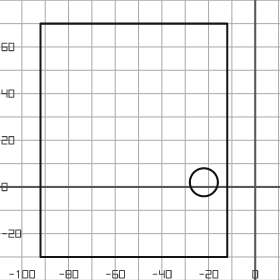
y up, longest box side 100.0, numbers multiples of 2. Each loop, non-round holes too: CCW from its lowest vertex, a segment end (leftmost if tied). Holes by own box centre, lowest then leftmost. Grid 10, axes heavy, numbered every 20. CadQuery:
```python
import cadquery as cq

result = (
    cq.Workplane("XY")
    .moveTo(-92.0, -30.0)
    .lineTo(-12.0, -30.0)
    .lineTo(-12.0, 70.0)
    .lineTo(-92.0, 70.0)
    .close()
    .moveTo(-22.0, 2.0)
    .circle(6.0)
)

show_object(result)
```